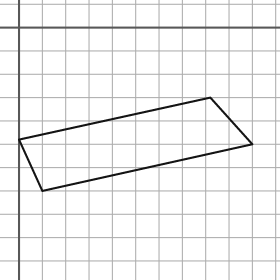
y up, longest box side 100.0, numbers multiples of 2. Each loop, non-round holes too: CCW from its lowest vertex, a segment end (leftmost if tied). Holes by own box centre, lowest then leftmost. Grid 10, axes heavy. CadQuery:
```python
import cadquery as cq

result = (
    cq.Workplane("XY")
    .moveTo(10.0, -70.0)
    .lineTo(100.0, -50.0)
    .lineTo(82.0, -30.0)
    .lineTo(0.0, -48.0)
    .close()
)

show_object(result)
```